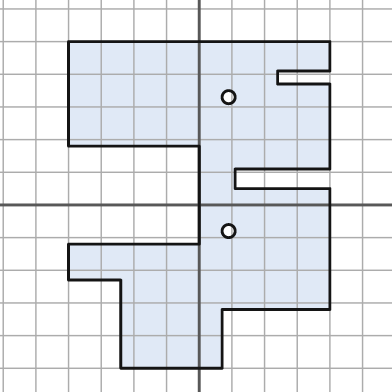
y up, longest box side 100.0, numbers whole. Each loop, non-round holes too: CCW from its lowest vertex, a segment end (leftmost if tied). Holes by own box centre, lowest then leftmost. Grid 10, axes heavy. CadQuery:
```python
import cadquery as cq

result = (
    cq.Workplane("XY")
    .moveTo(-24.0, -50.0)
    .lineTo(7.0, -50.0)
    .lineTo(7.0, -32.0)
    .lineTo(40.0, -32.0)
    .lineTo(40.0, 5.0)
    .lineTo(11.0, 5.0)
    .lineTo(11.0, 11.0)
    .lineTo(40.0, 11.0)
    .lineTo(40.0, 37.0)
    .lineTo(24.0, 37.0)
    .lineTo(24.0, 41.0)
    .lineTo(40.0, 41.0)
    .lineTo(40.0, 50.0)
    .lineTo(-40.0, 50.0)
    .lineTo(-40.0, 18.0)
    .lineTo(0.0, 18.0)
    .lineTo(0.0, -12.0)
    .lineTo(-40.0, -12.0)
    .lineTo(-40.0, -23.0)
    .lineTo(-24.0, -23.0)
    .close()
    .moveTo(9.0, -8.0)
    .circle(2.0)
    .moveTo(9.0, 33.0)
    .circle(2.0)
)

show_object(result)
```